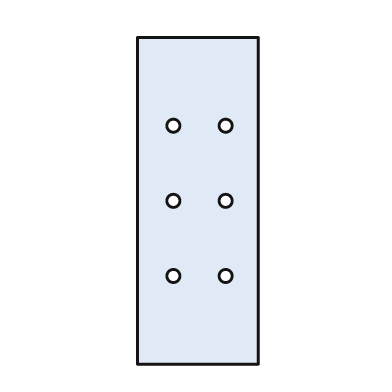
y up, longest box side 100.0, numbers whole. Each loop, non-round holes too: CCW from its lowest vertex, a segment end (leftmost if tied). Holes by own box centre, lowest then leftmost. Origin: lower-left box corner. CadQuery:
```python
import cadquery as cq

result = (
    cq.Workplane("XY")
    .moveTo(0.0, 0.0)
    .lineTo(37.0, 0.0)
    .lineTo(37.0, 100.0)
    .lineTo(0.0, 100.0)
    .close()
    .moveTo(11.0, 27.0)
    .circle(2.0)
    .moveTo(27.0, 27.0)
    .circle(2.0)
    .moveTo(11.0, 50.0)
    .circle(2.0)
    .moveTo(27.0, 50.0)
    .circle(2.0)
    .moveTo(11.0, 73.0)
    .circle(2.0)
    .moveTo(27.0, 73.0)
    .circle(2.0)
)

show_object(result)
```